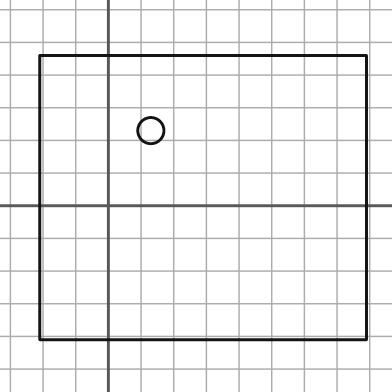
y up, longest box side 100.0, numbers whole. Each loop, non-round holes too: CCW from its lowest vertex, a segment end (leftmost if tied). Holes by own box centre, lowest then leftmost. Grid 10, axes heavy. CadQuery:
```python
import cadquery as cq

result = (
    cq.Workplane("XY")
    .moveTo(-21.0, -41.0)
    .lineTo(79.0, -41.0)
    .lineTo(79.0, 46.0)
    .lineTo(-21.0, 46.0)
    .close()
    .moveTo(13.0, 23.0)
    .circle(4.0)
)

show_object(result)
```